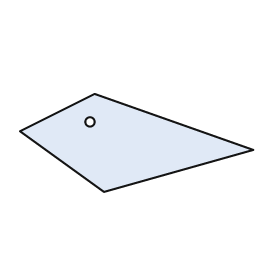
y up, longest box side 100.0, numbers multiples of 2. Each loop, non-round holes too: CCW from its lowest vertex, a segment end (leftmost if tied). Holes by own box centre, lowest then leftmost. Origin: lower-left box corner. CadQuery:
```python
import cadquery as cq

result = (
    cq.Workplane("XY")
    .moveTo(36.0, 0.0)
    .lineTo(100.0, 18.0)
    .lineTo(32.0, 42.0)
    .lineTo(0.0, 26.0)
    .close()
    .moveTo(30.0, 30.0)
    .circle(2.0)
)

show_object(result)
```